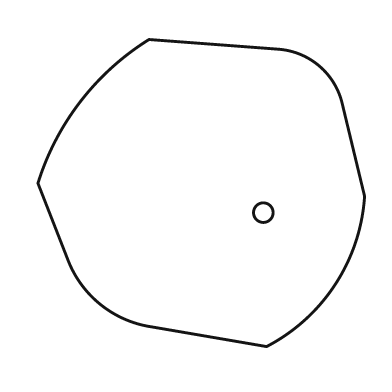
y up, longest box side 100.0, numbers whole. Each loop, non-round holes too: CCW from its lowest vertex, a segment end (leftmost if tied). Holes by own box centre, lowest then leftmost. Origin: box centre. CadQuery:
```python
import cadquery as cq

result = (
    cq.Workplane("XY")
    .moveTo(20.0, -47.0)
    .threePointArc((41.0, -28.0), (50.0, -1.0))
    .lineTo(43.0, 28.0)
    .threePointArc((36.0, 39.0), (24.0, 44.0))
    .lineTo(-16.0, 47.0)
    .threePointArc((-37.0, 28.0), (-50.0, 3.0))
    .lineTo(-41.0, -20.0)
    .threePointArc((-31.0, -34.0), (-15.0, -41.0))
    .close()
    .moveTo(19.0, -6.0)
    .circle(3.0)
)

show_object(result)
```